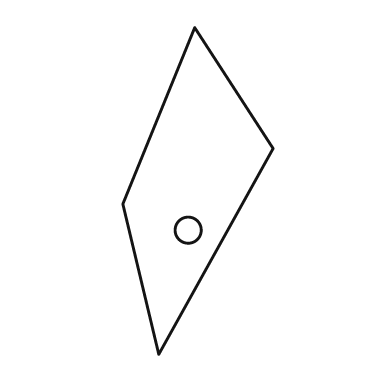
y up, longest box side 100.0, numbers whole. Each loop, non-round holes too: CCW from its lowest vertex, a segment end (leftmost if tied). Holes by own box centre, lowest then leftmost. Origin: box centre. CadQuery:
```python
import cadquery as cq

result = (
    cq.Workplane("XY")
    .moveTo(-12.0, -50.0)
    .lineTo(23.0, 13.0)
    .lineTo(-1.0, 50.0)
    .lineTo(-23.0, -4.0)
    .close()
    .moveTo(-3.0, -12.0)
    .circle(4.0)
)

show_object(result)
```